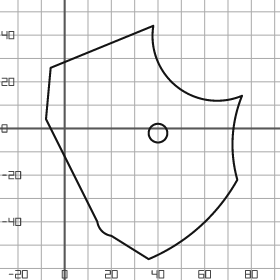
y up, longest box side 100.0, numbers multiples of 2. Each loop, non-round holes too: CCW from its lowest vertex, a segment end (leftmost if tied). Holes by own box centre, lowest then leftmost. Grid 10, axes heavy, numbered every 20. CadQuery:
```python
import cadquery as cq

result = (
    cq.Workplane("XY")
    .moveTo(36.0, -56.0)
    .threePointArc((58.0, -42.0), (74.0, -22.0))
    .threePointArc((72.0, -4.0), (76.0, 14.0))
    .threePointArc((48.0, 18.0), (38.0, 44.0))
    .lineTo(-6.0, 26.0)
    .lineTo(-8.0, 4.0)
    .lineTo(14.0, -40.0)
    .threePointArc((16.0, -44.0), (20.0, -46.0))
    .close()
    .moveTo(40.0, -2.0)
    .circle(4.0)
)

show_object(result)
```